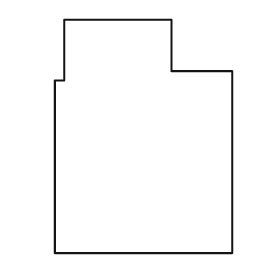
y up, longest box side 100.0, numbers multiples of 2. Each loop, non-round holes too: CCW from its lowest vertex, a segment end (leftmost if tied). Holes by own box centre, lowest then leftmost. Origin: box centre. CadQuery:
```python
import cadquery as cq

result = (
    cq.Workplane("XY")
    .moveTo(-38.0, -50.0)
    .lineTo(38.0, -50.0)
    .lineTo(38.0, 28.0)
    .lineTo(12.0, 28.0)
    .lineTo(12.0, 50.0)
    .lineTo(-34.0, 50.0)
    .lineTo(-34.0, 24.0)
    .lineTo(-38.0, 24.0)
    .close()
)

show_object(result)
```